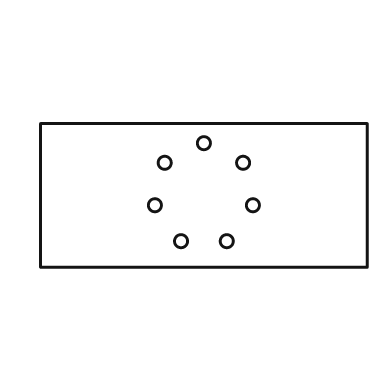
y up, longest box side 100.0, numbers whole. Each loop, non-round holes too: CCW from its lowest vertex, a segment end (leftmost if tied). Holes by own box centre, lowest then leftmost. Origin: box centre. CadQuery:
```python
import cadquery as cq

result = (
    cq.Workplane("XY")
    .moveTo(-50.0, -22.0)
    .lineTo(50.0, -22.0)
    .lineTo(50.0, 22.0)
    .lineTo(-50.0, 22.0)
    .close()
    .moveTo(-7.0, -14.0)
    .circle(2.0)
    .moveTo(7.0, -14.0)
    .circle(2.0)
    .moveTo(-15.0, -3.0)
    .circle(2.0)
    .moveTo(15.0, -3.0)
    .circle(2.0)
    .moveTo(-12.0, 10.0)
    .circle(2.0)
    .moveTo(12.0, 10.0)
    .circle(2.0)
    .moveTo(0.0, 16.0)
    .circle(2.0)
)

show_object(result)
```